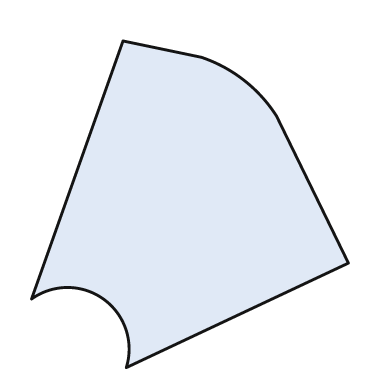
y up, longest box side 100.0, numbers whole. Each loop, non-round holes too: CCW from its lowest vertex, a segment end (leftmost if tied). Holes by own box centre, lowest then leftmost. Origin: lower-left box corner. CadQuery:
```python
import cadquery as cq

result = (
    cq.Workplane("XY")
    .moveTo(29.0, 0.0)
    .lineTo(97.0, 32.0)
    .lineTo(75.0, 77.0)
    .threePointArc((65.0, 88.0), (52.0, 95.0))
    .lineTo(28.0, 100.0)
    .lineTo(0.0, 21.0)
    .threePointArc((22.0, 21.0), (29.0, 0.0))
    .close()
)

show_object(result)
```